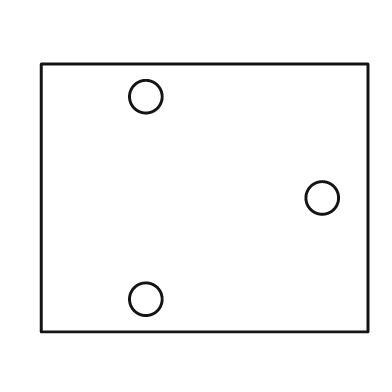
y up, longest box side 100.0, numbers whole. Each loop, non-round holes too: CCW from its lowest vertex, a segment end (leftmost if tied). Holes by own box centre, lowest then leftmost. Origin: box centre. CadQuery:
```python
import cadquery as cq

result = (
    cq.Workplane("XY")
    .moveTo(-50.0, -41.0)
    .lineTo(50.0, -41.0)
    .lineTo(50.0, 41.0)
    .lineTo(-50.0, 41.0)
    .close()
    .moveTo(-18.0, -31.0)
    .circle(5.0)
    .moveTo(36.0, 0.0)
    .circle(5.0)
    .moveTo(-18.0, 31.0)
    .circle(5.0)
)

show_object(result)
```